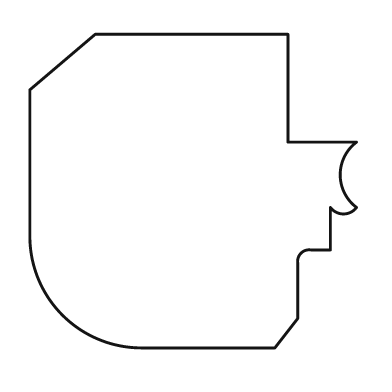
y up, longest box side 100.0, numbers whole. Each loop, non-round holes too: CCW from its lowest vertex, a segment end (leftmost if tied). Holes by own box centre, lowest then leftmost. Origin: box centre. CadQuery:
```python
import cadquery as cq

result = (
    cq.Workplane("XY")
    .moveTo(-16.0, -48.0)
    .lineTo(25.0, -48.0)
    .lineTo(32.0, -39.0)
    .lineTo(32.0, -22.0)
    .threePointArc((33.0, -19.0), (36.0, -18.0))
    .lineTo(42.0, -18.0)
    .lineTo(42.0, -5.0)
    .threePointArc((46.0, -7.0), (50.0, -5.0))
    .threePointArc((45.0, 5.0), (50.0, 15.0))
    .lineTo(29.0, 15.0)
    .lineTo(29.0, 48.0)
    .lineTo(-30.0, 48.0)
    .lineTo(-50.0, 31.0)
    .lineTo(-50.0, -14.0)
    .threePointArc((-40.0, -38.0), (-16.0, -48.0))
    .close()
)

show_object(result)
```